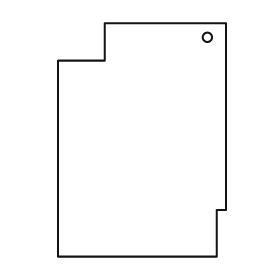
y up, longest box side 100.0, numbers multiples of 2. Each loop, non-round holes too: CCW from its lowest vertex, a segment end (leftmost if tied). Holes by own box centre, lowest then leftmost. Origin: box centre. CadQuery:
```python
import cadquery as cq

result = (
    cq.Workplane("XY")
    .moveTo(-36.0, -50.0)
    .lineTo(32.0, -50.0)
    .lineTo(32.0, -30.0)
    .lineTo(36.0, -30.0)
    .lineTo(36.0, 50.0)
    .lineTo(-16.0, 50.0)
    .lineTo(-16.0, 34.0)
    .lineTo(-36.0, 34.0)
    .close()
    .moveTo(28.0, 44.0)
    .circle(2.0)
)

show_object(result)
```